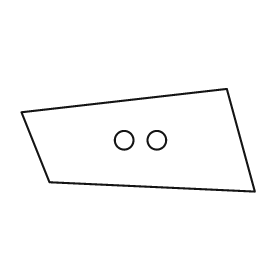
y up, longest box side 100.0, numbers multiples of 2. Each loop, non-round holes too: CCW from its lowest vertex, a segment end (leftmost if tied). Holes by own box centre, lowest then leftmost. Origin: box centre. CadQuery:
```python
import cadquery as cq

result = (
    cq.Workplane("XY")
    .moveTo(50.0, -22.0)
    .lineTo(38.0, 22.0)
    .lineTo(-50.0, 12.0)
    .lineTo(-38.0, -18.0)
    .close()
    .moveTo(-6.0, 0.0)
    .circle(4.0)
    .moveTo(8.0, 0.0)
    .circle(4.0)
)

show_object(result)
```